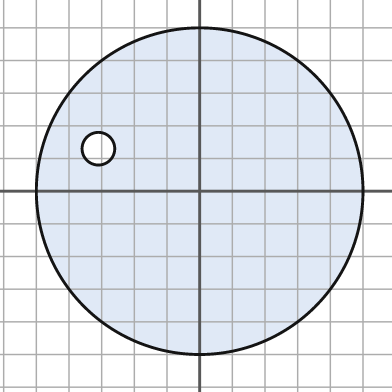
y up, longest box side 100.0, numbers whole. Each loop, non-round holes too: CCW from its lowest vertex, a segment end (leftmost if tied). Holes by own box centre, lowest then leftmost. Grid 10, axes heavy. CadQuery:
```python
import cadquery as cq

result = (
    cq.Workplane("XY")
    .moveTo(0.0, 0.0)
    .circle(50.0)
    .moveTo(-31.0, 13.0)
    .circle(5.0)
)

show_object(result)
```